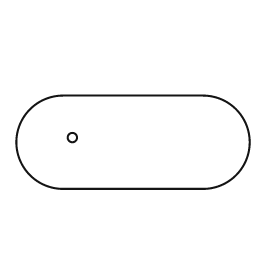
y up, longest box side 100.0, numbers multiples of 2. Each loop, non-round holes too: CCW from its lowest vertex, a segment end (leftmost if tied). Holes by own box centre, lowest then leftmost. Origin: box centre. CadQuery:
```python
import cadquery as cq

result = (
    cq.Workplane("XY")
    .moveTo(-30.0, -20.0)
    .lineTo(30.0, -20.0)
    .threePointArc((50.0, 0.0), (30.0, 20.0))
    .lineTo(-30.0, 20.0)
    .threePointArc((-50.0, 0.0), (-30.0, -20.0))
    .close()
    .moveTo(-26.0, 2.0)
    .circle(2.0)
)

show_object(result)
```